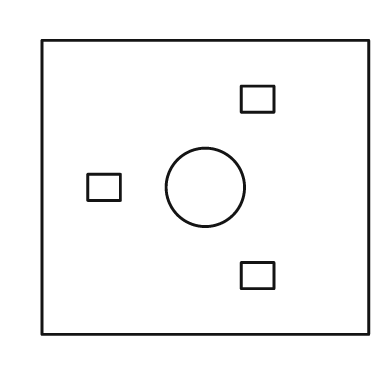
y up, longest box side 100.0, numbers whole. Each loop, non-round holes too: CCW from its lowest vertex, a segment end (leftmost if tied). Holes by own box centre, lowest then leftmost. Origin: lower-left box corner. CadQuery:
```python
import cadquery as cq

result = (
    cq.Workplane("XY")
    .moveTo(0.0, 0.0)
    .lineTo(100.0, 0.0)
    .lineTo(100.0, 90.0)
    .lineTo(0.0, 90.0)
    .close()
    .moveTo(61.0, 14.0)
    .lineTo(71.0, 14.0)
    .lineTo(71.0, 22.0)
    .lineTo(61.0, 22.0)
    .close()
    .moveTo(14.0, 41.0)
    .lineTo(24.0, 41.0)
    .lineTo(24.0, 49.0)
    .lineTo(14.0, 49.0)
    .close()
    .moveTo(50.0, 45.0)
    .circle(12.0)
    .moveTo(61.0, 68.0)
    .lineTo(71.0, 68.0)
    .lineTo(71.0, 76.0)
    .lineTo(61.0, 76.0)
    .close()
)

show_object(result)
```